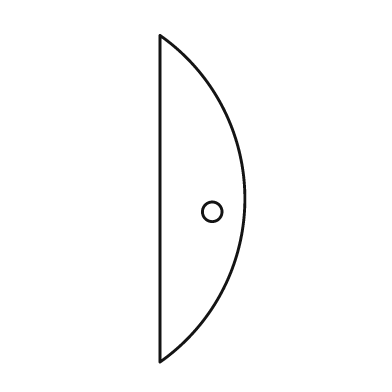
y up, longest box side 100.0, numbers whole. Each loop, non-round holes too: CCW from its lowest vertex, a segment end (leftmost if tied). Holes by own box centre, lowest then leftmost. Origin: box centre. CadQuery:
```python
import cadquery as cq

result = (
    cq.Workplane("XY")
    .moveTo(-13.0, -50.0)
    .threePointArc((13.0, 0.0), (-13.0, 50.0))
    .close()
    .moveTo(3.0, -4.0)
    .circle(3.0)
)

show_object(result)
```